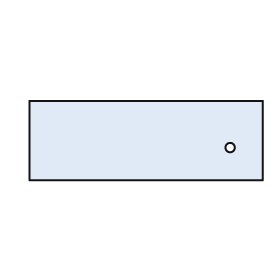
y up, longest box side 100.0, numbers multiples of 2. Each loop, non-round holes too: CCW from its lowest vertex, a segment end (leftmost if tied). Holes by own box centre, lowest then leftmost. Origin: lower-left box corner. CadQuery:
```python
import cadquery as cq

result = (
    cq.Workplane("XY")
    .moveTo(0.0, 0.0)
    .lineTo(100.0, 0.0)
    .lineTo(100.0, 34.0)
    .lineTo(0.0, 34.0)
    .close()
    .moveTo(86.0, 14.0)
    .circle(2.0)
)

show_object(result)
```